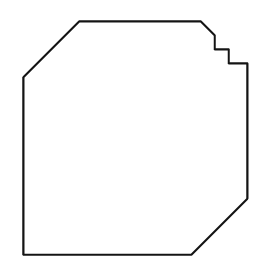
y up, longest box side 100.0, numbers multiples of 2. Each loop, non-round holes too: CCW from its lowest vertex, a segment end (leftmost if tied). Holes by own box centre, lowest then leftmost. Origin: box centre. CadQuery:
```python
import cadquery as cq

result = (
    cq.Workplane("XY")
    .moveTo(-48.0, -50.0)
    .lineTo(24.0, -50.0)
    .lineTo(48.0, -26.0)
    .lineTo(48.0, 32.0)
    .lineTo(40.0, 32.0)
    .lineTo(40.0, 38.0)
    .lineTo(34.0, 38.0)
    .lineTo(34.0, 44.0)
    .lineTo(28.0, 50.0)
    .lineTo(-24.0, 50.0)
    .lineTo(-48.0, 26.0)
    .close()
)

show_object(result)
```